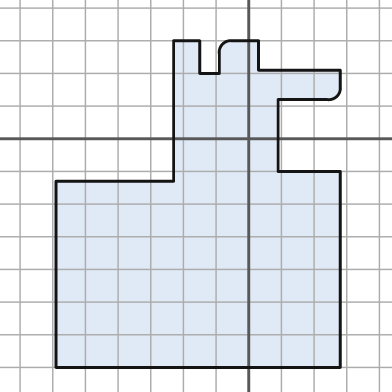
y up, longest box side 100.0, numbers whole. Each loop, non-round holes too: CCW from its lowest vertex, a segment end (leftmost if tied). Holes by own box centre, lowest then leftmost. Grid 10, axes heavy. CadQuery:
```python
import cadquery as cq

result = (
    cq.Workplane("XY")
    .moveTo(-59.0, -70.0)
    .lineTo(28.0, -70.0)
    .lineTo(28.0, -10.0)
    .lineTo(9.0, -10.0)
    .lineTo(9.0, 12.0)
    .lineTo(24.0, 12.0)
    .threePointArc((27.0, 13.0), (28.0, 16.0))
    .lineTo(28.0, 21.0)
    .lineTo(3.0, 21.0)
    .lineTo(3.0, 30.0)
    .lineTo(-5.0, 30.0)
    .threePointArc((-8.0, 29.0), (-9.0, 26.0))
    .lineTo(-9.0, 20.0)
    .lineTo(-15.0, 20.0)
    .lineTo(-15.0, 30.0)
    .lineTo(-23.0, 30.0)
    .lineTo(-23.0, -13.0)
    .lineTo(-59.0, -13.0)
    .close()
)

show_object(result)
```